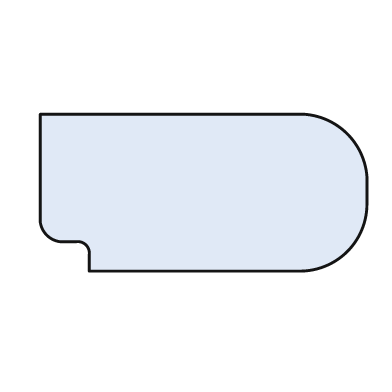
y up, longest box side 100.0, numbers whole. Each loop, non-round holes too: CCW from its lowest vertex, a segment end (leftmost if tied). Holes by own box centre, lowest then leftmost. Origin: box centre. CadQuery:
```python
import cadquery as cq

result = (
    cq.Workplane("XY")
    .moveTo(-35.0, -24.0)
    .lineTo(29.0, -24.0)
    .threePointArc((44.0, -18.0), (50.0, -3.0))
    .lineTo(50.0, 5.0)
    .threePointArc((44.0, 18.0), (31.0, 24.0))
    .lineTo(-50.0, 24.0)
    .lineTo(-50.0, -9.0)
    .threePointArc((-48.0, -13.0), (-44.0, -15.0))
    .lineTo(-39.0, -15.0)
    .threePointArc((-36.0, -16.0), (-35.0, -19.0))
    .close()
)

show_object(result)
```